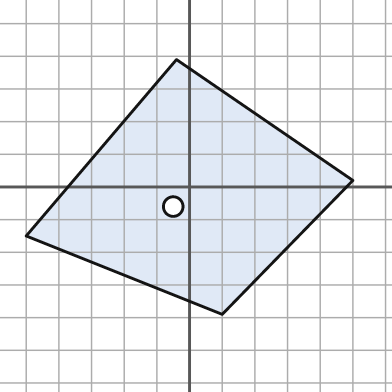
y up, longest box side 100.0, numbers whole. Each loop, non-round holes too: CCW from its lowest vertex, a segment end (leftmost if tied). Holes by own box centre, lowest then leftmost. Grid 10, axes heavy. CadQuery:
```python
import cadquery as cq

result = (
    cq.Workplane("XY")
    .moveTo(10.0, -39.0)
    .lineTo(50.0, 2.0)
    .lineTo(-4.0, 39.0)
    .lineTo(-50.0, -15.0)
    .close()
    .moveTo(-5.0, -6.0)
    .circle(3.0)
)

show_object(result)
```